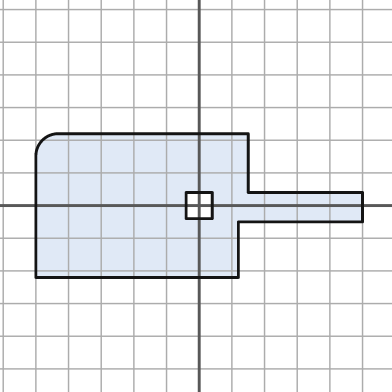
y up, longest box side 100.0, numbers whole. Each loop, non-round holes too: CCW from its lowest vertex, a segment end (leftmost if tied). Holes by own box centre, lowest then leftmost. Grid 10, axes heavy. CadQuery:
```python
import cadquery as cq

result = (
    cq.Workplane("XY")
    .moveTo(-50.0, -22.0)
    .lineTo(12.0, -22.0)
    .lineTo(12.0, -5.0)
    .lineTo(50.0, -5.0)
    .lineTo(50.0, 4.0)
    .lineTo(15.0, 4.0)
    .lineTo(15.0, 22.0)
    .lineTo(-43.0, 22.0)
    .threePointArc((-48.0, 20.0), (-50.0, 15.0))
    .close()
    .moveTo(-4.0, -4.0)
    .lineTo(4.0, -4.0)
    .lineTo(4.0, 4.0)
    .lineTo(-4.0, 4.0)
    .close()
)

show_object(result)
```